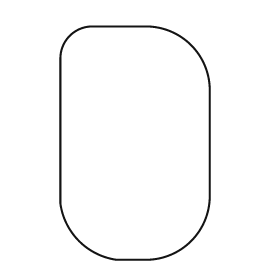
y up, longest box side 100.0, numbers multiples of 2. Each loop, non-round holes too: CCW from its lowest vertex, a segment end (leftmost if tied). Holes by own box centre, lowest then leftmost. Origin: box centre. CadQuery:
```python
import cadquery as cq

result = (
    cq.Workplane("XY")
    .moveTo(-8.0, -50.0)
    .lineTo(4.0, -50.0)
    .threePointArc((24.0, -42.0), (32.0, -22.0))
    .lineTo(32.0, 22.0)
    .threePointArc((24.0, 42.0), (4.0, 50.0))
    .lineTo(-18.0, 50.0)
    .threePointArc((-28.0, 46.0), (-32.0, 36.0))
    .lineTo(-32.0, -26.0)
    .threePointArc((-24.0, -42.0), (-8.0, -50.0))
    .close()
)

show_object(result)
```